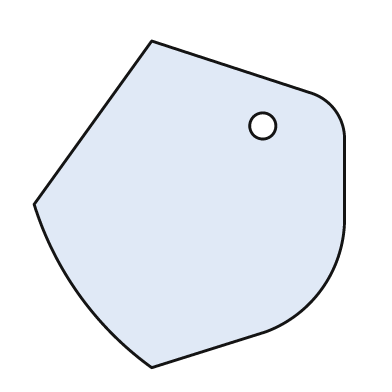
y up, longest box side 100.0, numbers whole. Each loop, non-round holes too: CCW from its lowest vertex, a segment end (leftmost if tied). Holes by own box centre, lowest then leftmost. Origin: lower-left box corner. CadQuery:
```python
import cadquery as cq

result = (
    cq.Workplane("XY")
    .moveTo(36.0, 0.0)
    .lineTo(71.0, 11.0)
    .threePointArc((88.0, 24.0), (95.0, 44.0))
    .lineTo(95.0, 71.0)
    .threePointArc((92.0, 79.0), (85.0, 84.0))
    .lineTo(36.0, 100.0)
    .lineTo(0.0, 50.0)
    .threePointArc((14.0, 22.0), (36.0, 0.0))
    .close()
    .moveTo(70.0, 74.0)
    .circle(4.0)
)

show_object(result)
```